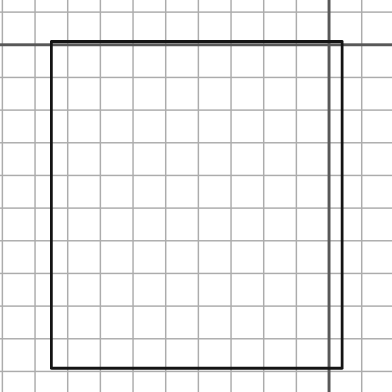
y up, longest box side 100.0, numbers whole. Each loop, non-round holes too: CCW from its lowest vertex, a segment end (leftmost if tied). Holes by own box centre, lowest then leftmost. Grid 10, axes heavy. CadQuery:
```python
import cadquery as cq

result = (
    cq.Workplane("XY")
    .moveTo(-85.0, -99.0)
    .lineTo(4.0, -99.0)
    .lineTo(4.0, 1.0)
    .lineTo(-85.0, 1.0)
    .close()
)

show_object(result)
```